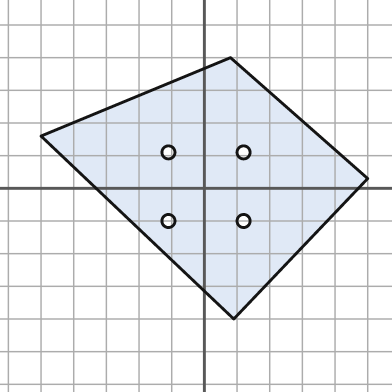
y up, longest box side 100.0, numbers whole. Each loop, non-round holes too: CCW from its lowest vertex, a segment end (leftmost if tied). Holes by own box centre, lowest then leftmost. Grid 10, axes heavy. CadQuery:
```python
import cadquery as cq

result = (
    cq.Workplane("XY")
    .moveTo(9.0, -40.0)
    .lineTo(50.0, 3.0)
    .lineTo(8.0, 40.0)
    .lineTo(-50.0, 16.0)
    .close()
    .moveTo(-11.0, -10.0)
    .circle(2.0)
    .moveTo(12.0, -10.0)
    .circle(2.0)
    .moveTo(-11.0, 11.0)
    .circle(2.0)
    .moveTo(12.0, 11.0)
    .circle(2.0)
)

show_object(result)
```